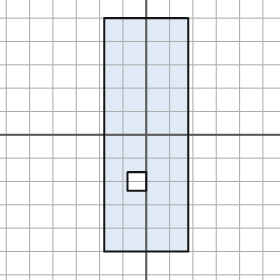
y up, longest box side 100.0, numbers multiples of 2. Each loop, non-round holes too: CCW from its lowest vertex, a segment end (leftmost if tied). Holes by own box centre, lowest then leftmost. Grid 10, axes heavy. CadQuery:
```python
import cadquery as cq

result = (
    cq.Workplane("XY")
    .moveTo(-18.0, -50.0)
    .lineTo(18.0, -50.0)
    .lineTo(18.0, 50.0)
    .lineTo(-18.0, 50.0)
    .close()
    .moveTo(-8.0, -24.0)
    .lineTo(0.0, -24.0)
    .lineTo(0.0, -16.0)
    .lineTo(-8.0, -16.0)
    .close()
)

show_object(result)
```